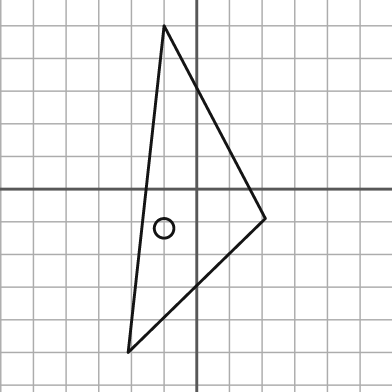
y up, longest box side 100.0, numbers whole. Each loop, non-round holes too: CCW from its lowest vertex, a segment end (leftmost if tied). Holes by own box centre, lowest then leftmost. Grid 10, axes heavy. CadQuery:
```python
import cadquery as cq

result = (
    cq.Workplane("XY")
    .moveTo(-21.0, -50.0)
    .lineTo(21.0, -9.0)
    .lineTo(-10.0, 50.0)
    .close()
    .moveTo(-10.0, -12.0)
    .circle(3.0)
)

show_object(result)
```